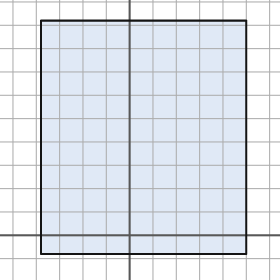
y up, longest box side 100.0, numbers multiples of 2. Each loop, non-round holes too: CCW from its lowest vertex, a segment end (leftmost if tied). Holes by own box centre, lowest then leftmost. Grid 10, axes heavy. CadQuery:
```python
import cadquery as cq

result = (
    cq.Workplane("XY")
    .moveTo(-38.0, -8.0)
    .lineTo(50.0, -8.0)
    .lineTo(50.0, 92.0)
    .lineTo(-38.0, 92.0)
    .close()
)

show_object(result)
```